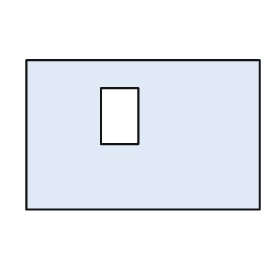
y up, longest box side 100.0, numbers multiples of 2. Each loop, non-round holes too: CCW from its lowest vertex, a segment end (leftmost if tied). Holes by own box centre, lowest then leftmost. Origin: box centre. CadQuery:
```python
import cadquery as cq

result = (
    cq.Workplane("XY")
    .moveTo(-50.0, -32.0)
    .lineTo(50.0, -32.0)
    .lineTo(50.0, 32.0)
    .lineTo(-50.0, 32.0)
    .close()
    .moveTo(-18.0, -4.0)
    .lineTo(-2.0, -4.0)
    .lineTo(-2.0, 20.0)
    .lineTo(-18.0, 20.0)
    .close()
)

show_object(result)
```